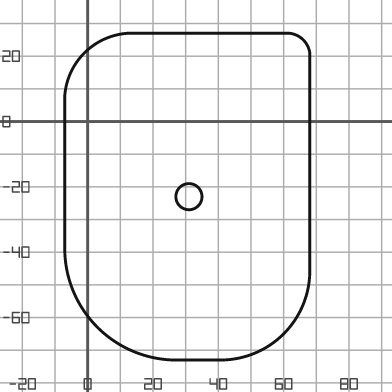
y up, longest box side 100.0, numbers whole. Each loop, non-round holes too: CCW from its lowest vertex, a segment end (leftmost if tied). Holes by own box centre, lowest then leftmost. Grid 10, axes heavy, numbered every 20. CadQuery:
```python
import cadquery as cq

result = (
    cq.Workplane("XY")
    .moveTo(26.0, -73.0)
    .lineTo(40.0, -73.0)
    .threePointArc((60.0, -65.0), (68.0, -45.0))
    .lineTo(68.0, 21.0)
    .threePointArc((66.0, 25.0), (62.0, 27.0))
    .lineTo(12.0, 27.0)
    .threePointArc((-1.0, 21.0), (-7.0, 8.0))
    .lineTo(-7.0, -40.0)
    .threePointArc((3.0, -63.0), (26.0, -73.0))
    .close()
    .moveTo(31.0, -23.0)
    .circle(4.0)
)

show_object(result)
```